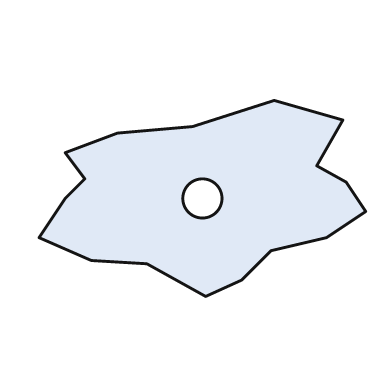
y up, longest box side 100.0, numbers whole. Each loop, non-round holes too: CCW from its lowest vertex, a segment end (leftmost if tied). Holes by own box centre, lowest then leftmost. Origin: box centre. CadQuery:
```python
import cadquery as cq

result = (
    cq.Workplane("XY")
    .moveTo(1.0, -30.0)
    .lineTo(12.0, -25.0)
    .lineTo(21.0, -16.0)
    .lineTo(38.0, -12.0)
    .lineTo(50.0, -4.0)
    .lineTo(44.0, 5.0)
    .lineTo(35.0, 10.0)
    .lineTo(43.0, 24.0)
    .lineTo(22.0, 30.0)
    .lineTo(-3.0, 22.0)
    .lineTo(-26.0, 20.0)
    .lineTo(-42.0, 14.0)
    .lineTo(-36.0, 6.0)
    .lineTo(-42.0, 0.0)
    .lineTo(-50.0, -12.0)
    .lineTo(-34.0, -19.0)
    .lineTo(-17.0, -20.0)
    .close()
    .moveTo(0.0, 0.0)
    .circle(6.0)
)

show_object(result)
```